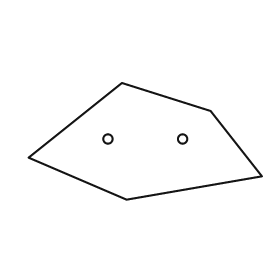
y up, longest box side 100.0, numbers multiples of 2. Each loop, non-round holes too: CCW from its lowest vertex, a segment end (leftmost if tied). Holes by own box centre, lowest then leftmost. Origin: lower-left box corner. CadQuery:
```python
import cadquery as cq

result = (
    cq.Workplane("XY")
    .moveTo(42.0, 0.0)
    .lineTo(100.0, 10.0)
    .lineTo(78.0, 38.0)
    .lineTo(40.0, 50.0)
    .lineTo(0.0, 18.0)
    .close()
    .moveTo(34.0, 26.0)
    .circle(2.0)
    .moveTo(66.0, 26.0)
    .circle(2.0)
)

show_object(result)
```